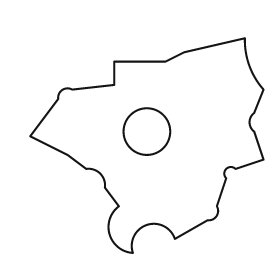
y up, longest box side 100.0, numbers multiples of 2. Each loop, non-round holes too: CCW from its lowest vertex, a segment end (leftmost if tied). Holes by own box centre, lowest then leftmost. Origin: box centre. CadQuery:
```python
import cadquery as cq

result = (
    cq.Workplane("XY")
    .moveTo(-6.0, -46.0)
    .threePointArc((0.0, -34.0), (12.0, -40.0))
    .lineTo(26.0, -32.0)
    .threePointArc((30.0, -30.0), (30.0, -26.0))
    .lineTo(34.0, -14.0)
    .threePointArc((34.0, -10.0), (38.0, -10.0))
    .lineTo(50.0, -6.0)
    .lineTo(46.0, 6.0)
    .threePointArc((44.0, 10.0), (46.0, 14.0))
    .lineTo(50.0, 24.0)
    .threePointArc((44.0, 34.0), (42.0, 46.0))
    .lineTo(16.0, 40.0)
    .lineTo(8.0, 36.0)
    .lineTo(-14.0, 36.0)
    .lineTo(-14.0, 26.0)
    .lineTo(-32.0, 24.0)
    .threePointArc((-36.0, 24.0), (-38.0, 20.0))
    .lineTo(-50.0, 4.0)
    .lineTo(-34.0, -4.0)
    .lineTo(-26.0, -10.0)
    .threePointArc((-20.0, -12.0), (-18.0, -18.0))
    .lineTo(-12.0, -26.0)
    .threePointArc((-16.0, -38.0), (-6.0, -46.0))
    .close()
    .moveTo(0.0, 6.0)
    .circle(10.0)
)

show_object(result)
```